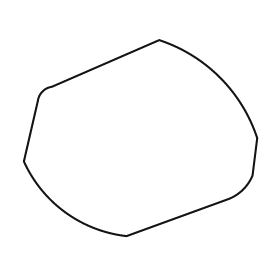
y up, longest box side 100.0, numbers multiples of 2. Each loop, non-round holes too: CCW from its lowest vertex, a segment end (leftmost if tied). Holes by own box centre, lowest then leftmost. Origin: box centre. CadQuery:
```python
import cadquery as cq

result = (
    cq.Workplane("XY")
    .moveTo(-6.0, -42.0)
    .lineTo(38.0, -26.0)
    .threePointArc((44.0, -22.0), (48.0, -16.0))
    .lineTo(50.0, 0.0)
    .threePointArc((34.0, 26.0), (8.0, 42.0))
    .lineTo(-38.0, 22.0)
    .threePointArc((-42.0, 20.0), (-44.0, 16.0))
    .lineTo(-50.0, -10.0)
    .threePointArc((-32.0, -32.0), (-6.0, -42.0))
    .close()
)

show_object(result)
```